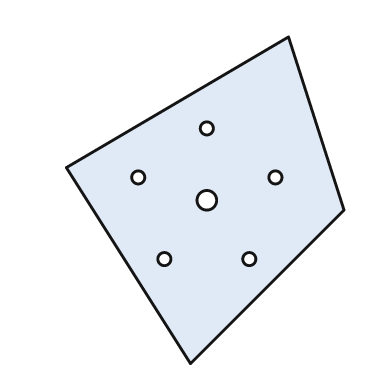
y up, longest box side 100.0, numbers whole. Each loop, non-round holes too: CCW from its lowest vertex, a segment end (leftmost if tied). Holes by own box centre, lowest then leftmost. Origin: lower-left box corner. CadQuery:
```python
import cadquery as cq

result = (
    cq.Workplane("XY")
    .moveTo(38.0, 0.0)
    .lineTo(85.0, 47.0)
    .lineTo(68.0, 100.0)
    .lineTo(0.0, 60.0)
    .close()
    .moveTo(30.0, 32.0)
    .circle(2.0)
    .moveTo(56.0, 32.0)
    .circle(2.0)
    .moveTo(43.0, 50.0)
    .circle(3.0)
    .moveTo(22.0, 57.0)
    .circle(2.0)
    .moveTo(64.0, 57.0)
    .circle(2.0)
    .moveTo(43.0, 72.0)
    .circle(2.0)
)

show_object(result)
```